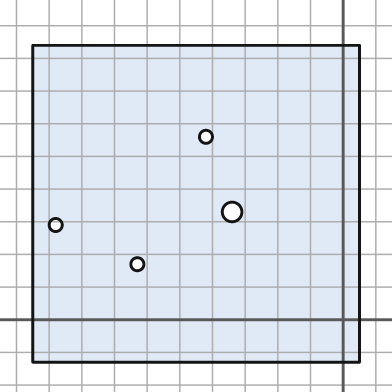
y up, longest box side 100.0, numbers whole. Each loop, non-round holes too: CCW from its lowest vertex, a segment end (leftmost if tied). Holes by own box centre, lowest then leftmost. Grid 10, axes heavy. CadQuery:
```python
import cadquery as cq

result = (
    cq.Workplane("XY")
    .moveTo(-95.0, -13.0)
    .lineTo(5.0, -13.0)
    .lineTo(5.0, 84.0)
    .lineTo(-95.0, 84.0)
    .close()
    .moveTo(-63.0, 17.0)
    .circle(2.0)
    .moveTo(-88.0, 29.0)
    .circle(2.0)
    .moveTo(-34.0, 33.0)
    .circle(3.0)
    .moveTo(-42.0, 56.0)
    .circle(2.0)
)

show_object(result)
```